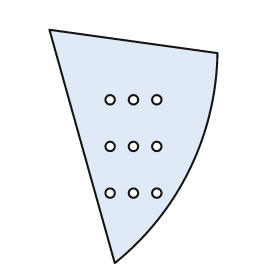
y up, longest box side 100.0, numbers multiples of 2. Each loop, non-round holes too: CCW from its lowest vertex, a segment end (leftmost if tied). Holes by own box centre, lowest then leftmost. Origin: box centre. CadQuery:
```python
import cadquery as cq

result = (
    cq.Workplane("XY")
    .moveTo(-8.0, -50.0)
    .threePointArc((24.0, -10.0), (36.0, 40.0))
    .lineTo(-36.0, 50.0)
    .close()
    .moveTo(-10.0, -20.0)
    .circle(2.0)
    .moveTo(0.0, -20.0)
    .circle(2.0)
    .moveTo(10.0, -20.0)
    .circle(2.0)
    .moveTo(-10.0, 0.0)
    .circle(2.0)
    .moveTo(0.0, 0.0)
    .circle(2.0)
    .moveTo(10.0, 0.0)
    .circle(2.0)
    .moveTo(-10.0, 20.0)
    .circle(2.0)
    .moveTo(0.0, 20.0)
    .circle(2.0)
    .moveTo(10.0, 20.0)
    .circle(2.0)
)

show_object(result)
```